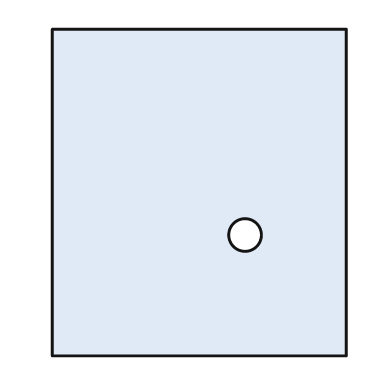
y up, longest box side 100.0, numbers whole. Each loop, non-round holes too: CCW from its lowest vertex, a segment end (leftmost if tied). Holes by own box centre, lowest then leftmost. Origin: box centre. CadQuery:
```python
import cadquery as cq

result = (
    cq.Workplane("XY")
    .moveTo(-45.0, -50.0)
    .lineTo(45.0, -50.0)
    .lineTo(45.0, 50.0)
    .lineTo(-45.0, 50.0)
    .close()
    .moveTo(14.0, -13.0)
    .circle(5.0)
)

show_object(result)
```